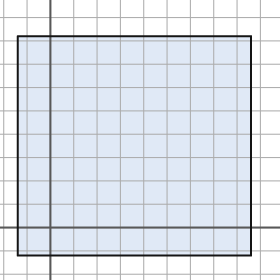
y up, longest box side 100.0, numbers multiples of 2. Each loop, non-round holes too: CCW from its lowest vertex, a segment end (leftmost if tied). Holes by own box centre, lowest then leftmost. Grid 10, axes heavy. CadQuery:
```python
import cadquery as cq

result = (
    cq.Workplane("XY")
    .moveTo(-14.0, -12.0)
    .lineTo(86.0, -12.0)
    .lineTo(86.0, 82.0)
    .lineTo(-14.0, 82.0)
    .close()
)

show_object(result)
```